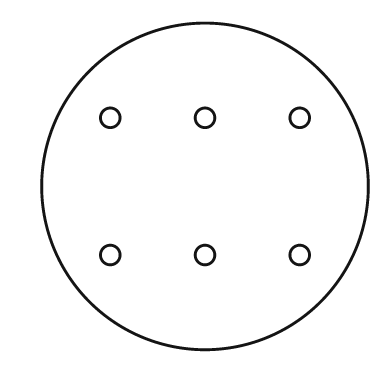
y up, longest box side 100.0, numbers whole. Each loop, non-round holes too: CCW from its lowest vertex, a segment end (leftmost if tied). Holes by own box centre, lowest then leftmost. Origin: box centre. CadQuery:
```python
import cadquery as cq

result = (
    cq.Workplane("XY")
    .moveTo(0.0, 0.0)
    .circle(50.0)
    .moveTo(-29.0, -21.0)
    .circle(3.0)
    .moveTo(0.0, -21.0)
    .circle(3.0)
    .moveTo(29.0, -21.0)
    .circle(3.0)
    .moveTo(-29.0, 21.0)
    .circle(3.0)
    .moveTo(0.0, 21.0)
    .circle(3.0)
    .moveTo(29.0, 21.0)
    .circle(3.0)
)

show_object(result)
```